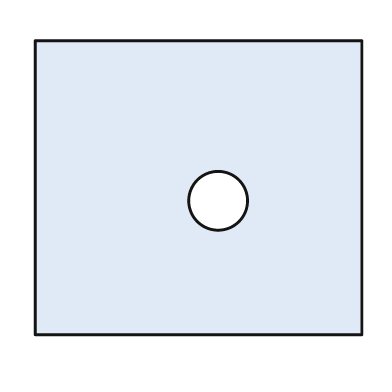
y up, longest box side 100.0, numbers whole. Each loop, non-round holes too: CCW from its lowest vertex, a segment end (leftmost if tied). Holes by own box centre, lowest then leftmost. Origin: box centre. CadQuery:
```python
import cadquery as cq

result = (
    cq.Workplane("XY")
    .moveTo(-50.0, -45.0)
    .lineTo(50.0, -45.0)
    .lineTo(50.0, 45.0)
    .lineTo(-50.0, 45.0)
    .close()
    .moveTo(6.0, -4.0)
    .circle(9.0)
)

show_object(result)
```